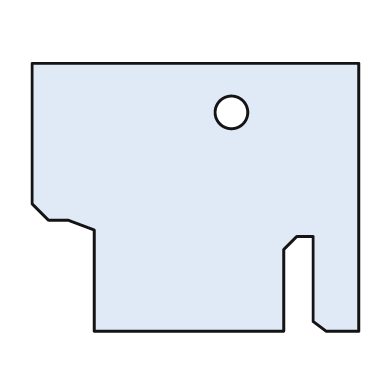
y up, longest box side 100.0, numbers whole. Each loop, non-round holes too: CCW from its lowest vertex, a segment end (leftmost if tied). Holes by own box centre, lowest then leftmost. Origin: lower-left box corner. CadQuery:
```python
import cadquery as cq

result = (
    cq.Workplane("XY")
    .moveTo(19.0, 0.0)
    .lineTo(77.0, 0.0)
    .lineTo(77.0, 25.0)
    .lineTo(81.0, 29.0)
    .lineTo(86.0, 29.0)
    .lineTo(86.0, 3.0)
    .lineTo(90.0, 0.0)
    .lineTo(100.0, 0.0)
    .lineTo(100.0, 82.0)
    .lineTo(0.0, 82.0)
    .lineTo(0.0, 39.0)
    .lineTo(5.0, 34.0)
    .lineTo(11.0, 34.0)
    .lineTo(19.0, 31.0)
    .close()
    .moveTo(61.0, 67.0)
    .circle(5.0)
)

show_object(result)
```